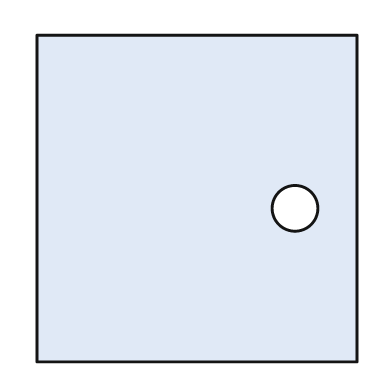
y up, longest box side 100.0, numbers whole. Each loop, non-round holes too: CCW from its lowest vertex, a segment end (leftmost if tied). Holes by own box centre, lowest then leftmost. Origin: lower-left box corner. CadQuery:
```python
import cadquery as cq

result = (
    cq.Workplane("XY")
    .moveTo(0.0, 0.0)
    .lineTo(98.0, 0.0)
    .lineTo(98.0, 100.0)
    .lineTo(0.0, 100.0)
    .close()
    .moveTo(79.0, 47.0)
    .circle(7.0)
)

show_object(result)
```